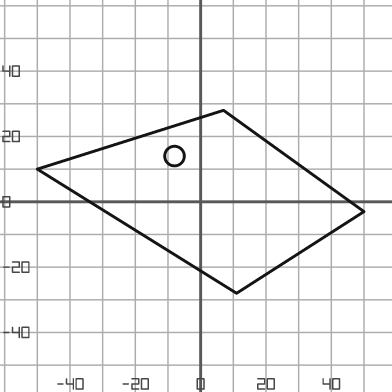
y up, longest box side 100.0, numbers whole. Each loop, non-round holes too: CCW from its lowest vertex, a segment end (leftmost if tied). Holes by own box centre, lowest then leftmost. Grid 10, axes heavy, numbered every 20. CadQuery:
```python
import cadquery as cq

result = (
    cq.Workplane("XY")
    .moveTo(11.0, -28.0)
    .lineTo(50.0, -3.0)
    .lineTo(7.0, 28.0)
    .lineTo(-50.0, 10.0)
    .close()
    .moveTo(-8.0, 14.0)
    .circle(3.0)
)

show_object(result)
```